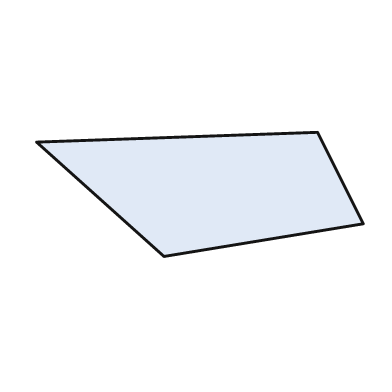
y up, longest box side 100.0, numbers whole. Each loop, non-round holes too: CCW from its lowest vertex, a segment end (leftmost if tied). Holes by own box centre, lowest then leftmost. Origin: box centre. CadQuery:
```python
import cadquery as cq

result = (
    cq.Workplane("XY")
    .moveTo(-11.0, -19.0)
    .lineTo(50.0, -9.0)
    .lineTo(36.0, 19.0)
    .lineTo(-50.0, 16.0)
    .close()
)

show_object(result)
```